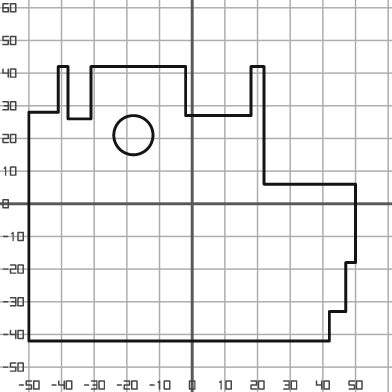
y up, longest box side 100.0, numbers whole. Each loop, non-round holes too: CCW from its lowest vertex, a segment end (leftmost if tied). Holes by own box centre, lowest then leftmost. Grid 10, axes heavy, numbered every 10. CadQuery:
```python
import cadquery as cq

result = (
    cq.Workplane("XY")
    .moveTo(-50.0, -42.0)
    .lineTo(42.0, -42.0)
    .lineTo(42.0, -33.0)
    .lineTo(47.0, -33.0)
    .lineTo(47.0, -18.0)
    .lineTo(50.0, -18.0)
    .lineTo(50.0, 6.0)
    .lineTo(22.0, 6.0)
    .lineTo(22.0, 42.0)
    .lineTo(18.0, 42.0)
    .lineTo(18.0, 27.0)
    .lineTo(-2.0, 27.0)
    .lineTo(-2.0, 42.0)
    .lineTo(-31.0, 42.0)
    .lineTo(-31.0, 26.0)
    .lineTo(-38.0, 26.0)
    .lineTo(-38.0, 42.0)
    .lineTo(-41.0, 42.0)
    .lineTo(-41.0, 28.0)
    .lineTo(-50.0, 28.0)
    .close()
    .moveTo(-18.0, 21.0)
    .circle(6.0)
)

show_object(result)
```